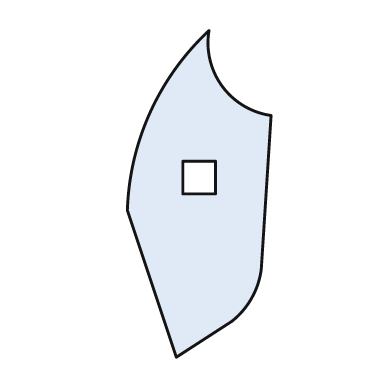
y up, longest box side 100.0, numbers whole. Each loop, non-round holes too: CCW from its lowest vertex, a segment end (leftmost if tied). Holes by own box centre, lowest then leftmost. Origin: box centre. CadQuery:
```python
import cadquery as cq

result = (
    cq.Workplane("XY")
    .moveTo(-7.0, -50.0)
    .lineTo(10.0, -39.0)
    .threePointArc((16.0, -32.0), (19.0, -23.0))
    .lineTo(22.0, 24.0)
    .threePointArc((7.0, 33.0), (3.0, 50.0))
    .threePointArc((-15.0, 25.0), (-22.0, -5.0))
    .close()
    .moveTo(-5.0, 0.0)
    .lineTo(5.0, 0.0)
    .lineTo(5.0, 10.0)
    .lineTo(-5.0, 10.0)
    .close()
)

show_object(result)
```